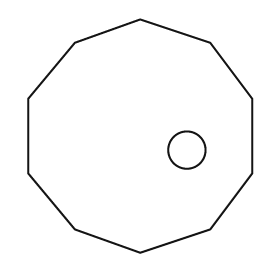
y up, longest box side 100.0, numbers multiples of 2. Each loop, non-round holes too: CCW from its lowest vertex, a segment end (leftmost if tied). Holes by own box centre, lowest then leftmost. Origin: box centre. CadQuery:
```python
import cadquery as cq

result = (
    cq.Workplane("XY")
    .moveTo(0.0, -50.0)
    .lineTo(30.0, -40.0)
    .lineTo(48.0, -16.0)
    .lineTo(48.0, 16.0)
    .lineTo(30.0, 40.0)
    .lineTo(0.0, 50.0)
    .lineTo(-28.0, 40.0)
    .lineTo(-48.0, 16.0)
    .lineTo(-48.0, -16.0)
    .lineTo(-28.0, -40.0)
    .close()
    .moveTo(20.0, -6.0)
    .circle(8.0)
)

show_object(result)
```